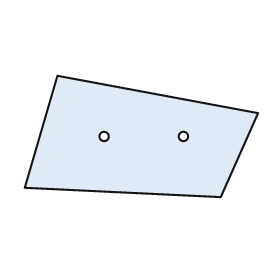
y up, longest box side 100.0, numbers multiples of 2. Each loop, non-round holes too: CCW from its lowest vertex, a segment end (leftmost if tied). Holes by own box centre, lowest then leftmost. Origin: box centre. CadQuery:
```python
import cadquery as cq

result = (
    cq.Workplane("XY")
    .moveTo(34.0, -26.0)
    .lineTo(50.0, 10.0)
    .lineTo(-36.0, 26.0)
    .lineTo(-50.0, -22.0)
    .close()
    .moveTo(-16.0, 0.0)
    .circle(2.0)
    .moveTo(18.0, 0.0)
    .circle(2.0)
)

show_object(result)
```